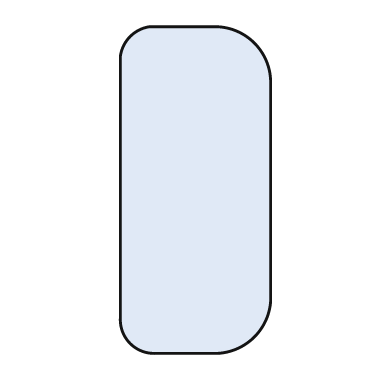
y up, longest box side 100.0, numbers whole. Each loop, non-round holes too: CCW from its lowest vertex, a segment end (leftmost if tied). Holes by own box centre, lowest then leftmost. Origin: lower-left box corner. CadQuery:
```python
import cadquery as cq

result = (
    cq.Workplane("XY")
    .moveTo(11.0, 0.0)
    .lineTo(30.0, 0.0)
    .threePointArc((41.0, 5.0), (46.0, 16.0))
    .lineTo(46.0, 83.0)
    .threePointArc((41.0, 95.0), (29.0, 100.0))
    .lineTo(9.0, 100.0)
    .threePointArc((3.0, 97.0), (0.0, 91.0))
    .lineTo(0.0, 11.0)
    .threePointArc((3.0, 3.0), (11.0, 0.0))
    .close()
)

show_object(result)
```